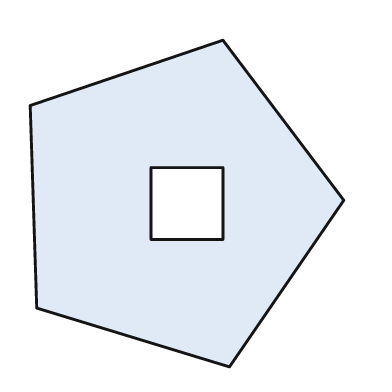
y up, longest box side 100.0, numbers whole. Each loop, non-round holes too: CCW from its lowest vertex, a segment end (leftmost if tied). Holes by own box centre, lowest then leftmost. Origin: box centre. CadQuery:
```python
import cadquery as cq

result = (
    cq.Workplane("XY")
    .moveTo(13.0, -50.0)
    .lineTo(48.0, 1.0)
    .lineTo(11.0, 50.0)
    .lineTo(-48.0, 30.0)
    .lineTo(-46.0, -32.0)
    .close()
    .moveTo(-11.0, -11.0)
    .lineTo(11.0, -11.0)
    .lineTo(11.0, 11.0)
    .lineTo(-11.0, 11.0)
    .close()
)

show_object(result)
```